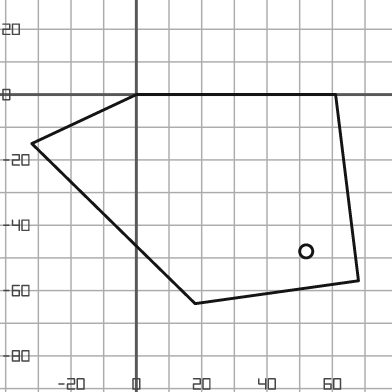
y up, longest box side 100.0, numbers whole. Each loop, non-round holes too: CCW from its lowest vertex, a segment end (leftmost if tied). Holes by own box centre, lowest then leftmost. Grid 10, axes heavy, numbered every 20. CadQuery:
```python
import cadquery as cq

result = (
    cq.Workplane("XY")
    .moveTo(18.0, -64.0)
    .lineTo(68.0, -57.0)
    .lineTo(61.0, 0.0)
    .lineTo(0.0, 0.0)
    .lineTo(-32.0, -15.0)
    .close()
    .moveTo(52.0, -48.0)
    .circle(2.0)
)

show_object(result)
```